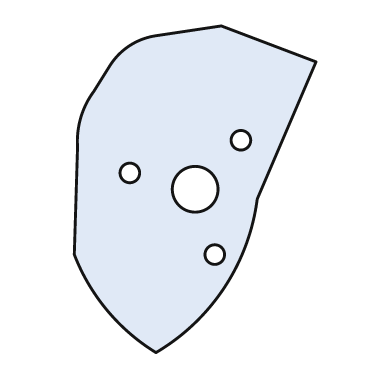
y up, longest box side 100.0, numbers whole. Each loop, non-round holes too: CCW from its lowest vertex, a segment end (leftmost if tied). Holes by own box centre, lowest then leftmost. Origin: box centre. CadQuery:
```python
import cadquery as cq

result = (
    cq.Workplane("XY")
    .moveTo(-12.0, -50.0)
    .threePointArc((9.0, -30.0), (19.0, -3.0))
    .lineTo(37.0, 39.0)
    .lineTo(8.0, 50.0)
    .lineTo(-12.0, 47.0)
    .threePointArc((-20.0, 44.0), (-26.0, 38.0))
    .lineTo(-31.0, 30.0)
    .threePointArc((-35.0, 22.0), (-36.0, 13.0))
    .lineTo(-37.0, -20.0)
    .threePointArc((-27.0, -37.0), (-12.0, -50.0))
    .close()
    .moveTo(6.0, -20.0)
    .circle(3.0)
    .moveTo(0.0, 0.0)
    .circle(7.0)
    .moveTo(-20.0, 5.0)
    .circle(3.0)
    .moveTo(14.0, 15.0)
    .circle(3.0)
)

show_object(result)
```